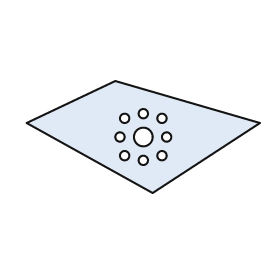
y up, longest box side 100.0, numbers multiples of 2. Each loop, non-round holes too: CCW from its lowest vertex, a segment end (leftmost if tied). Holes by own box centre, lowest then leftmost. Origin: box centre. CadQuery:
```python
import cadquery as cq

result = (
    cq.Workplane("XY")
    .moveTo(4.0, -24.0)
    .lineTo(50.0, 6.0)
    .lineTo(-12.0, 24.0)
    .lineTo(-50.0, 6.0)
    .close()
    .moveTo(0.0, -10.0)
    .circle(2.0)
    .moveTo(-8.0, -8.0)
    .circle(2.0)
    .moveTo(8.0, -8.0)
    .circle(2.0)
    .moveTo(-10.0, 0.0)
    .circle(2.0)
    .moveTo(0.0, 0.0)
    .circle(4.0)
    .moveTo(10.0, 0.0)
    .circle(2.0)
    .moveTo(-8.0, 8.0)
    .circle(2.0)
    .moveTo(8.0, 8.0)
    .circle(2.0)
    .moveTo(0.0, 10.0)
    .circle(2.0)
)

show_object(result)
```